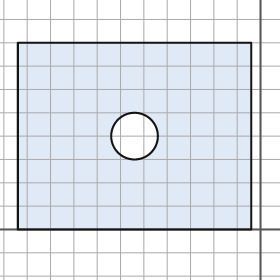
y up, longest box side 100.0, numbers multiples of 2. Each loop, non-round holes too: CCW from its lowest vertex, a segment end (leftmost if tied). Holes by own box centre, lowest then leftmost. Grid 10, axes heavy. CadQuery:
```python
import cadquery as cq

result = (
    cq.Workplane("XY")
    .moveTo(-104.0, 0.0)
    .lineTo(-4.0, 0.0)
    .lineTo(-4.0, 80.0)
    .lineTo(-104.0, 80.0)
    .close()
    .moveTo(-54.0, 40.0)
    .circle(10.0)
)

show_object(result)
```